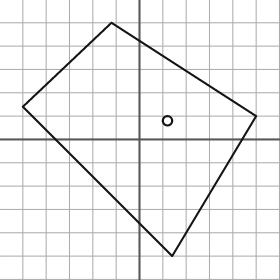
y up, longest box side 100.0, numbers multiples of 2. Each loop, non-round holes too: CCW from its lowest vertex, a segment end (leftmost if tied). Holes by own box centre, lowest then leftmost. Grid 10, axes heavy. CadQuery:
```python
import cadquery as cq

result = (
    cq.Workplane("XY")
    .moveTo(14.0, -50.0)
    .lineTo(50.0, 10.0)
    .lineTo(-12.0, 50.0)
    .lineTo(-50.0, 14.0)
    .close()
    .moveTo(12.0, 8.0)
    .circle(2.0)
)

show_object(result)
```